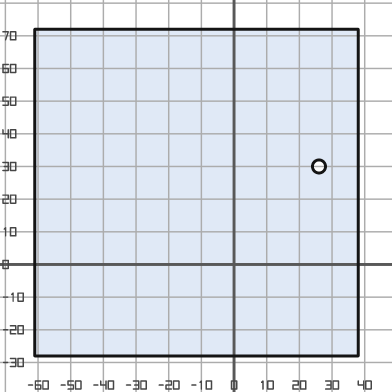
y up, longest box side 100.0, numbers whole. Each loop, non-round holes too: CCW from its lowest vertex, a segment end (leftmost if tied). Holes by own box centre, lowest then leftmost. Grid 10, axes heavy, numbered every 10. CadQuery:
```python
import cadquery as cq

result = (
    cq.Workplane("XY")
    .moveTo(-61.0, -28.0)
    .lineTo(38.0, -28.0)
    .lineTo(38.0, 72.0)
    .lineTo(-61.0, 72.0)
    .close()
    .moveTo(26.0, 30.0)
    .circle(2.0)
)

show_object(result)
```